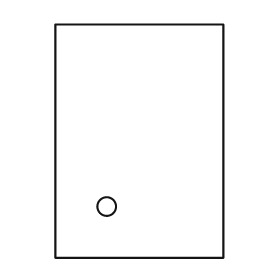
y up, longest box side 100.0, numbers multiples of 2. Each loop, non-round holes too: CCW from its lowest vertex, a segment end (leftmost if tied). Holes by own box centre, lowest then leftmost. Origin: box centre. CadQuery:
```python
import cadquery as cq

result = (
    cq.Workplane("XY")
    .moveTo(-36.0, -50.0)
    .lineTo(36.0, -50.0)
    .lineTo(36.0, 50.0)
    .lineTo(-36.0, 50.0)
    .close()
    .moveTo(-14.0, -28.0)
    .circle(4.0)
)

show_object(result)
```